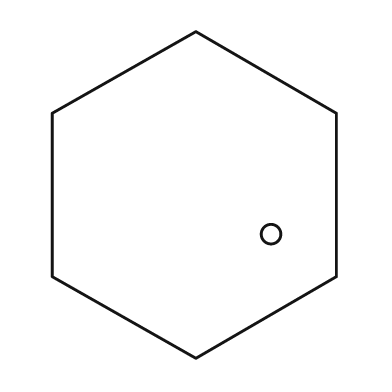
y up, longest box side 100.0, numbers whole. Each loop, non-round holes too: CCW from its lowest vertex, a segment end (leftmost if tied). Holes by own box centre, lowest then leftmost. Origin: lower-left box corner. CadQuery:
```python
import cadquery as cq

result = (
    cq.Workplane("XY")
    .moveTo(44.0, 0.0)
    .lineTo(87.0, 25.0)
    .lineTo(87.0, 75.0)
    .lineTo(44.0, 100.0)
    .lineTo(0.0, 75.0)
    .lineTo(0.0, 25.0)
    .close()
    .moveTo(67.0, 38.0)
    .circle(3.0)
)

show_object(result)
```